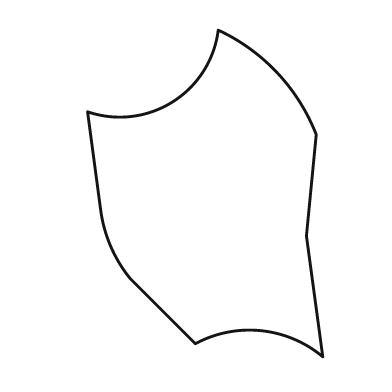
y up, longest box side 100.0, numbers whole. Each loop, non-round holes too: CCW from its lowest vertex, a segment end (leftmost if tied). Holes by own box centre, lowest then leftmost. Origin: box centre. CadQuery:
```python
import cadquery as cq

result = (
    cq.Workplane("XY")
    .moveTo(36.0, -50.0)
    .lineTo(31.0, -13.0)
    .lineTo(34.0, 18.0)
    .threePointArc((22.0, 37.0), (4.0, 50.0))
    .threePointArc((-10.0, 28.0), (-36.0, 25.0))
    .lineTo(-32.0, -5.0)
    .threePointArc((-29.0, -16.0), (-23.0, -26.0))
    .lineTo(-3.0, -46.0)
    .threePointArc((17.0, -42.0), (36.0, -50.0))
    .close()
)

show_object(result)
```